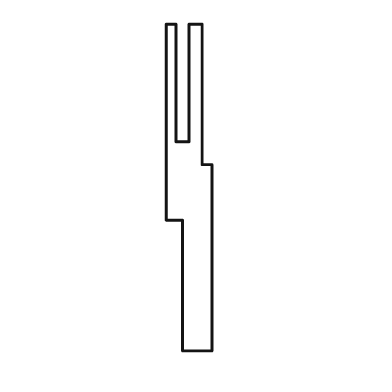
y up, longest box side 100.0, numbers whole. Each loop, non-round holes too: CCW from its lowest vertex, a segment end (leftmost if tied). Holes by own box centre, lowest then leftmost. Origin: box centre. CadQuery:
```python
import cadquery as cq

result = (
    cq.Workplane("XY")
    .moveTo(-2.0, -50.0)
    .lineTo(7.0, -50.0)
    .lineTo(7.0, 7.0)
    .lineTo(4.0, 7.0)
    .lineTo(4.0, 50.0)
    .lineTo(0.0, 50.0)
    .lineTo(0.0, 14.0)
    .lineTo(-4.0, 14.0)
    .lineTo(-4.0, 50.0)
    .lineTo(-7.0, 50.0)
    .lineTo(-7.0, -10.0)
    .lineTo(-2.0, -10.0)
    .close()
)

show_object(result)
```